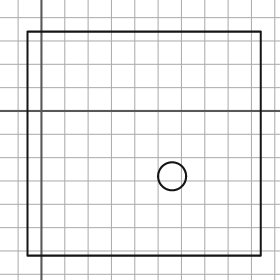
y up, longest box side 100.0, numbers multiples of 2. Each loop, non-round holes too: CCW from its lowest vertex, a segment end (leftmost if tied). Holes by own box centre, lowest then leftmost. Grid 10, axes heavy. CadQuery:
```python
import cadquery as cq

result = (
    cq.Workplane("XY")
    .moveTo(-6.0, -62.0)
    .lineTo(94.0, -62.0)
    .lineTo(94.0, 34.0)
    .lineTo(-6.0, 34.0)
    .close()
    .moveTo(56.0, -28.0)
    .circle(6.0)
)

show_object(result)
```